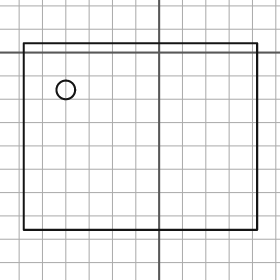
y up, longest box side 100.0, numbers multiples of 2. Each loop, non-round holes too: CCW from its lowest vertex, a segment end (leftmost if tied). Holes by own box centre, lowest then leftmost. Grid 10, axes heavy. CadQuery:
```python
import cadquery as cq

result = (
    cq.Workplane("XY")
    .moveTo(-58.0, -76.0)
    .lineTo(42.0, -76.0)
    .lineTo(42.0, 4.0)
    .lineTo(-58.0, 4.0)
    .close()
    .moveTo(-40.0, -16.0)
    .circle(4.0)
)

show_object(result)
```